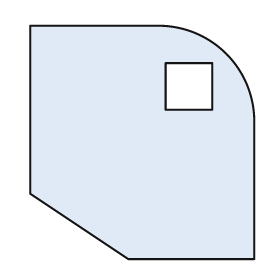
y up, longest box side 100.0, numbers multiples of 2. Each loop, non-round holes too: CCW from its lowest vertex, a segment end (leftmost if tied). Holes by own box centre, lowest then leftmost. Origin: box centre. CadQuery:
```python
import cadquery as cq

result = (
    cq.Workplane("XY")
    .moveTo(-6.0, -50.0)
    .lineTo(48.0, -50.0)
    .lineTo(48.0, 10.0)
    .threePointArc((36.0, 38.0), (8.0, 50.0))
    .lineTo(-48.0, 50.0)
    .lineTo(-48.0, -22.0)
    .close()
    .moveTo(10.0, 14.0)
    .lineTo(30.0, 14.0)
    .lineTo(30.0, 34.0)
    .lineTo(10.0, 34.0)
    .close()
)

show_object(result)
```